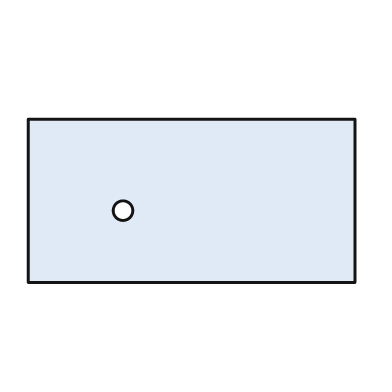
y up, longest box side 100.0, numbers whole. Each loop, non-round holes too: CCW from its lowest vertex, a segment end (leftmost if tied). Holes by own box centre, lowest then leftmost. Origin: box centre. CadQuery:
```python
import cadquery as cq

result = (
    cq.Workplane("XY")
    .moveTo(-50.0, -25.0)
    .lineTo(50.0, -25.0)
    .lineTo(50.0, 25.0)
    .lineTo(-50.0, 25.0)
    .close()
    .moveTo(-21.0, -3.0)
    .circle(3.0)
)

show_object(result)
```